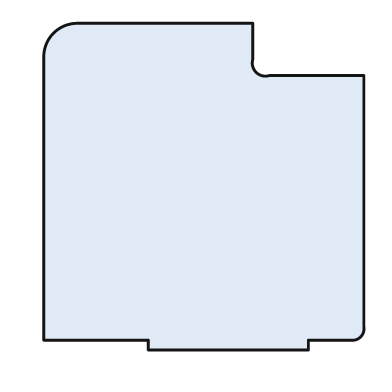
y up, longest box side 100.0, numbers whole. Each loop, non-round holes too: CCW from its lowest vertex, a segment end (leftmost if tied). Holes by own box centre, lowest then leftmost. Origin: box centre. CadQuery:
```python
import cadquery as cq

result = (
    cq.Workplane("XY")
    .moveTo(-17.0, -50.0)
    .lineTo(32.0, -50.0)
    .lineTo(32.0, -47.0)
    .lineTo(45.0, -47.0)
    .threePointArc((48.0, -46.0), (49.0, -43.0))
    .lineTo(49.0, 34.0)
    .lineTo(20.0, 34.0)
    .threePointArc((16.0, 35.0), (15.0, 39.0))
    .lineTo(15.0, 50.0)
    .lineTo(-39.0, 50.0)
    .threePointArc((-46.0, 47.0), (-49.0, 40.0))
    .lineTo(-49.0, -47.0)
    .lineTo(-17.0, -47.0)
    .close()
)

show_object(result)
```